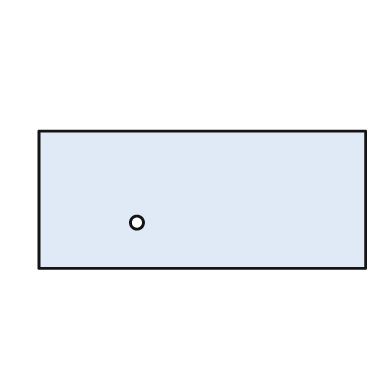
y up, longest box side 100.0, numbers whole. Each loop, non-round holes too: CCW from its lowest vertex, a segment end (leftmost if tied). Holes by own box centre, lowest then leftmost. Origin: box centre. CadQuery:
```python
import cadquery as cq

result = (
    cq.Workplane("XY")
    .moveTo(-50.0, -21.0)
    .lineTo(50.0, -21.0)
    .lineTo(50.0, 21.0)
    .lineTo(-50.0, 21.0)
    .close()
    .moveTo(-20.0, -7.0)
    .circle(2.0)
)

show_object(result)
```